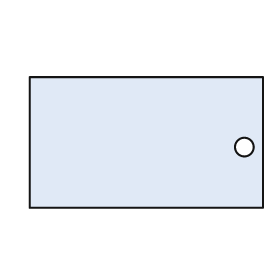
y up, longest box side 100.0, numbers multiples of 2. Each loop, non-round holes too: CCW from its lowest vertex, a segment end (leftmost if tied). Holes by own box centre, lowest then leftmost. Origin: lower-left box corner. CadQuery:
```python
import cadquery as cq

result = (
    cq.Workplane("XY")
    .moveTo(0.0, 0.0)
    .lineTo(100.0, 0.0)
    .lineTo(100.0, 56.0)
    .lineTo(0.0, 56.0)
    .close()
    .moveTo(92.0, 26.0)
    .circle(4.0)
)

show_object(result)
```